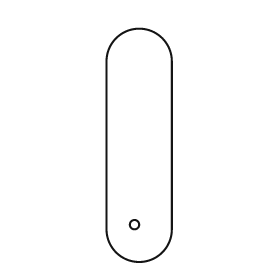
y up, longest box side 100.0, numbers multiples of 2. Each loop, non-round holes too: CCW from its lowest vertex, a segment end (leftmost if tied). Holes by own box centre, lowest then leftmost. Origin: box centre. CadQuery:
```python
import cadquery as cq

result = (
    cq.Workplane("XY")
    .moveTo(-14.0, -36.0)
    .threePointArc((0.0, -50.0), (14.0, -36.0))
    .lineTo(14.0, 36.0)
    .threePointArc((0.0, 50.0), (-14.0, 36.0))
    .close()
    .moveTo(-2.0, -34.0)
    .circle(2.0)
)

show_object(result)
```